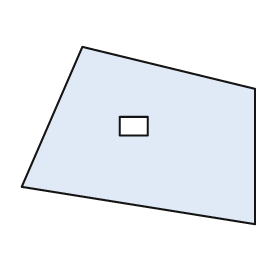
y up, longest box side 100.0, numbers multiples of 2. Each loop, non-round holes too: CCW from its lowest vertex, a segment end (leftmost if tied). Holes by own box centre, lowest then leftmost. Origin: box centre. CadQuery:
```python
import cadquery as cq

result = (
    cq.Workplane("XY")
    .moveTo(50.0, -38.0)
    .lineTo(50.0, 20.0)
    .lineTo(-24.0, 38.0)
    .lineTo(-50.0, -22.0)
    .close()
    .moveTo(-8.0, 0.0)
    .lineTo(4.0, 0.0)
    .lineTo(4.0, 8.0)
    .lineTo(-8.0, 8.0)
    .close()
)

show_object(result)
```